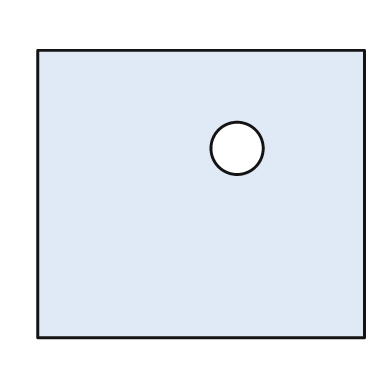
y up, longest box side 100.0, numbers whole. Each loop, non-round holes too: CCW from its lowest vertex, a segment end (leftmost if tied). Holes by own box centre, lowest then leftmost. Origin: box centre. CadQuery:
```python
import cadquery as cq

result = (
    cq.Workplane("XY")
    .moveTo(-50.0, -44.0)
    .lineTo(50.0, -44.0)
    .lineTo(50.0, 44.0)
    .lineTo(-50.0, 44.0)
    .close()
    .moveTo(11.0, 14.0)
    .circle(8.0)
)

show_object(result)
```